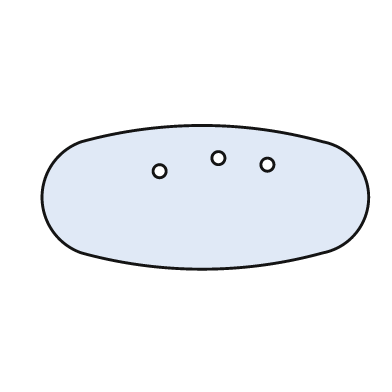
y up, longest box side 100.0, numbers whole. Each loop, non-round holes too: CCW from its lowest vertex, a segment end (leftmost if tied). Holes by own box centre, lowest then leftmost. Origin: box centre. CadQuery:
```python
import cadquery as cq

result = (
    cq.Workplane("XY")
    .moveTo(-38.0, -17.0)
    .threePointArc((-1.0, -22.0), (36.0, -17.0))
    .threePointArc((50.0, 0.0), (36.0, 17.0))
    .threePointArc((-1.0, 22.0), (-38.0, 17.0))
    .threePointArc((-50.0, 0.0), (-38.0, -17.0))
    .close()
    .moveTo(-14.0, 8.0)
    .circle(2.0)
    .moveTo(19.0, 10.0)
    .circle(2.0)
    .moveTo(4.0, 12.0)
    .circle(2.0)
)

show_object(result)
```